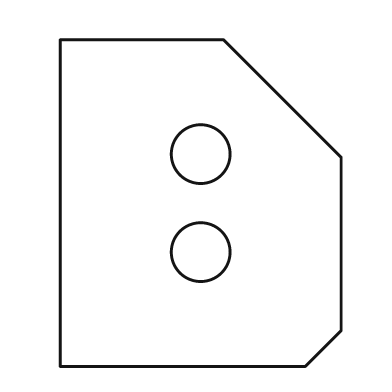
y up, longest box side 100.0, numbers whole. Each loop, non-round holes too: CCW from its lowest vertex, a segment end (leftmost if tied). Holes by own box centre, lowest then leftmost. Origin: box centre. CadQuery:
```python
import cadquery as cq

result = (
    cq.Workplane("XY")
    .moveTo(-43.0, -50.0)
    .lineTo(32.0, -50.0)
    .lineTo(43.0, -39.0)
    .lineTo(43.0, 14.0)
    .lineTo(7.0, 50.0)
    .lineTo(-43.0, 50.0)
    .close()
    .moveTo(0.0, -15.0)
    .circle(9.0)
    .moveTo(0.0, 15.0)
    .circle(9.0)
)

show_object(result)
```